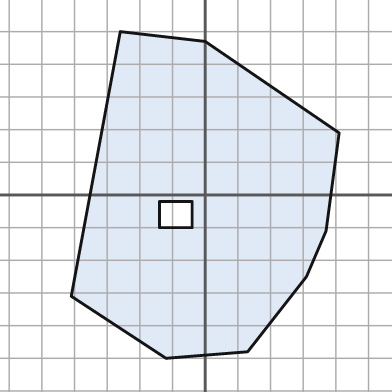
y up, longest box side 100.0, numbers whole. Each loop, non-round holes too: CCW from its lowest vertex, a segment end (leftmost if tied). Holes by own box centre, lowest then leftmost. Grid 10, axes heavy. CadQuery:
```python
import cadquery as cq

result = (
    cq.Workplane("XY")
    .moveTo(-12.0, -50.0)
    .lineTo(13.0, -48.0)
    .lineTo(31.0, -25.0)
    .lineTo(37.0, -11.0)
    .lineTo(41.0, 19.0)
    .lineTo(0.0, 47.0)
    .lineTo(-26.0, 50.0)
    .lineTo(-41.0, -31.0)
    .close()
    .moveTo(-14.0, -10.0)
    .lineTo(-4.0, -10.0)
    .lineTo(-4.0, -2.0)
    .lineTo(-14.0, -2.0)
    .close()
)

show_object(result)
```